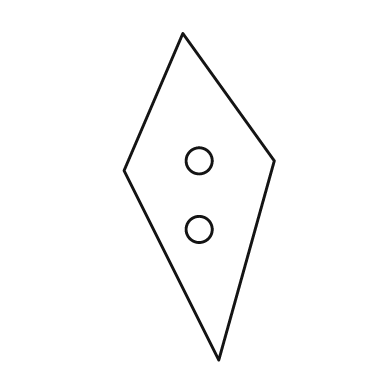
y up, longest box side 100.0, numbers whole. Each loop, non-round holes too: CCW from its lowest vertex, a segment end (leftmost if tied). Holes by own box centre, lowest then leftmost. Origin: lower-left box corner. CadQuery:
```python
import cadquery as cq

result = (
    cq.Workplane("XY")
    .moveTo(29.0, 0.0)
    .lineTo(46.0, 61.0)
    .lineTo(18.0, 100.0)
    .lineTo(0.0, 58.0)
    .close()
    .moveTo(23.0, 40.0)
    .circle(4.0)
    .moveTo(23.0, 61.0)
    .circle(4.0)
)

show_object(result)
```